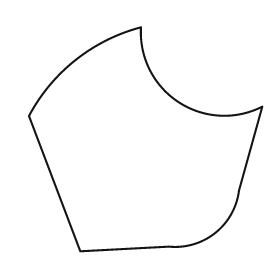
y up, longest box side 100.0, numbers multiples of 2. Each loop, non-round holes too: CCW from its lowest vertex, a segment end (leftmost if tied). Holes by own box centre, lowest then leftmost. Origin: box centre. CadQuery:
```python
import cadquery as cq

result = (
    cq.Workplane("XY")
    .moveTo(-28.0, -48.0)
    .lineTo(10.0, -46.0)
    .threePointArc((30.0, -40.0), (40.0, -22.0))
    .lineTo(50.0, 14.0)
    .threePointArc((14.0, 16.0), (-2.0, 48.0))
    .threePointArc((-30.0, 34.0), (-50.0, 10.0))
    .close()
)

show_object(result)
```